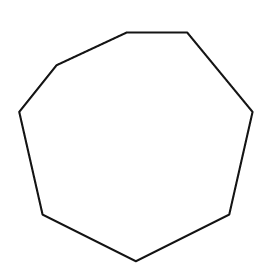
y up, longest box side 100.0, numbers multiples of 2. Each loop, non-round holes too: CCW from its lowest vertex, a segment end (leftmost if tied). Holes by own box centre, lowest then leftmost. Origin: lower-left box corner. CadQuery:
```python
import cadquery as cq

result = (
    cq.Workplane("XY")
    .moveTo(50.0, 0.0)
    .lineTo(90.0, 20.0)
    .lineTo(100.0, 64.0)
    .lineTo(72.0, 98.0)
    .lineTo(46.0, 98.0)
    .lineTo(16.0, 84.0)
    .lineTo(0.0, 64.0)
    .lineTo(10.0, 20.0)
    .close()
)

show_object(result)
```